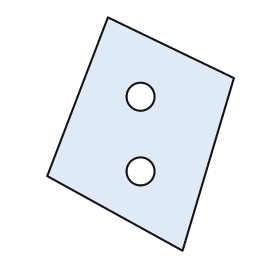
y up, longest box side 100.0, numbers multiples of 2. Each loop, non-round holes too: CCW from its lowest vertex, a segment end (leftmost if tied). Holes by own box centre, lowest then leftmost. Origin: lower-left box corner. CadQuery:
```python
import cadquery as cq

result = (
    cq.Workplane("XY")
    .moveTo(58.0, 0.0)
    .lineTo(80.0, 74.0)
    .lineTo(26.0, 100.0)
    .lineTo(0.0, 32.0)
    .close()
    .moveTo(40.0, 34.0)
    .circle(6.0)
    .moveTo(40.0, 66.0)
    .circle(6.0)
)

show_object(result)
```